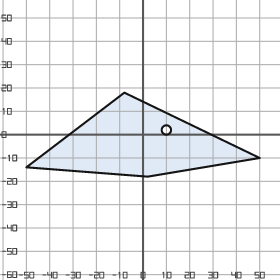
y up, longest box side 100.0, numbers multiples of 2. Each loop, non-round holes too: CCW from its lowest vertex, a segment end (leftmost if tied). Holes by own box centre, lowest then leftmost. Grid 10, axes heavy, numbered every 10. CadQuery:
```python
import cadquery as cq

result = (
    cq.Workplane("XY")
    .moveTo(2.0, -18.0)
    .lineTo(50.0, -10.0)
    .lineTo(-8.0, 18.0)
    .lineTo(-50.0, -14.0)
    .close()
    .moveTo(10.0, 2.0)
    .circle(2.0)
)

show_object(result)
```